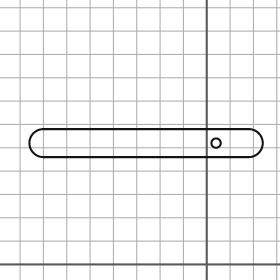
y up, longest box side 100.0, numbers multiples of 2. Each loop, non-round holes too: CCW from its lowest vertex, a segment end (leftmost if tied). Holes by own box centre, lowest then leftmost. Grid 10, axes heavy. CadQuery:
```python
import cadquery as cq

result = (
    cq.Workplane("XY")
    .moveTo(-70.0, 46.0)
    .lineTo(18.0, 46.0)
    .threePointArc((24.0, 52.0), (18.0, 58.0))
    .lineTo(-70.0, 58.0)
    .threePointArc((-76.0, 52.0), (-70.0, 46.0))
    .close()
    .moveTo(4.0, 52.0)
    .circle(2.0)
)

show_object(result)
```